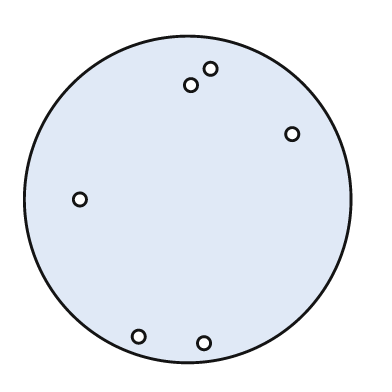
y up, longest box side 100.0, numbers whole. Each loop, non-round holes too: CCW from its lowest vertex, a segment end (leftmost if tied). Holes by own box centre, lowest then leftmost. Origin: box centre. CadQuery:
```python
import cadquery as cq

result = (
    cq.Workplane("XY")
    .moveTo(0.0, 0.0)
    .circle(50.0)
    .moveTo(5.0, -44.0)
    .circle(2.0)
    .moveTo(-15.0, -42.0)
    .circle(2.0)
    .moveTo(-33.0, 0.0)
    .circle(2.0)
    .moveTo(32.0, 20.0)
    .circle(2.0)
    .moveTo(1.0, 35.0)
    .circle(2.0)
    .moveTo(7.0, 40.0)
    .circle(2.0)
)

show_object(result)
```